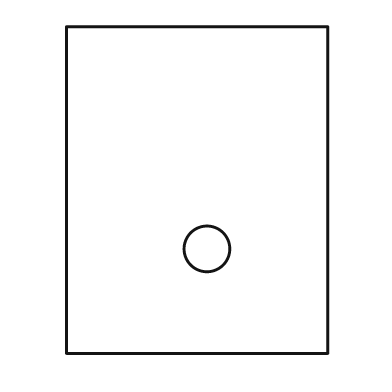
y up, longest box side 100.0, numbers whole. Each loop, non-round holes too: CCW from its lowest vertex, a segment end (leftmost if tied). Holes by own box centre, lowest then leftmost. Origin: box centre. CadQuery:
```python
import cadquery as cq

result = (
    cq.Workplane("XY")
    .moveTo(-40.0, -50.0)
    .lineTo(40.0, -50.0)
    .lineTo(40.0, 50.0)
    .lineTo(-40.0, 50.0)
    .close()
    .moveTo(3.0, -18.0)
    .circle(7.0)
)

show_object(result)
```